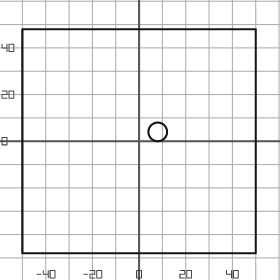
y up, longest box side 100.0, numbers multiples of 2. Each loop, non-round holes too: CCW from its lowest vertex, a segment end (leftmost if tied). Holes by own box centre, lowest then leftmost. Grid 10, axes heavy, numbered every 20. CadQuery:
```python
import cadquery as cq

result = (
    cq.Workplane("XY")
    .moveTo(-50.0, -48.0)
    .lineTo(50.0, -48.0)
    .lineTo(50.0, 48.0)
    .lineTo(-50.0, 48.0)
    .close()
    .moveTo(8.0, 4.0)
    .circle(4.0)
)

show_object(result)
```